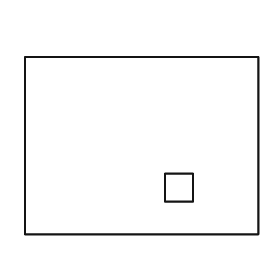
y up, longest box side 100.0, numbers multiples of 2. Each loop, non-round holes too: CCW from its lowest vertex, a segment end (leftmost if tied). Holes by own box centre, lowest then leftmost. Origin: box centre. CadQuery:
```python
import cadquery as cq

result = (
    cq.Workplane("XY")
    .moveTo(-50.0, -38.0)
    .lineTo(50.0, -38.0)
    .lineTo(50.0, 38.0)
    .lineTo(-50.0, 38.0)
    .close()
    .moveTo(10.0, -24.0)
    .lineTo(22.0, -24.0)
    .lineTo(22.0, -12.0)
    .lineTo(10.0, -12.0)
    .close()
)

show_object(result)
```